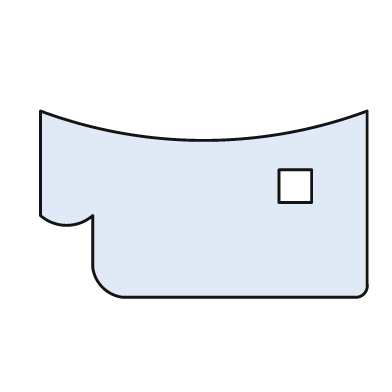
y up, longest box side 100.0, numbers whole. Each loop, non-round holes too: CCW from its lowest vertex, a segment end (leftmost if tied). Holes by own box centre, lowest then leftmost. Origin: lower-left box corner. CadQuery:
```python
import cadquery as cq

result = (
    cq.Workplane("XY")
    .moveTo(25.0, 0.0)
    .lineTo(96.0, 0.0)
    .threePointArc((99.0, 1.0), (100.0, 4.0))
    .lineTo(100.0, 57.0)
    .threePointArc((50.0, 48.0), (0.0, 57.0))
    .lineTo(0.0, 25.0)
    .threePointArc((8.0, 22.0), (16.0, 25.0))
    .lineTo(16.0, 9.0)
    .threePointArc((19.0, 3.0), (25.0, 0.0))
    .close()
    .moveTo(73.0, 29.0)
    .lineTo(83.0, 29.0)
    .lineTo(83.0, 39.0)
    .lineTo(73.0, 39.0)
    .close()
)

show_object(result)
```